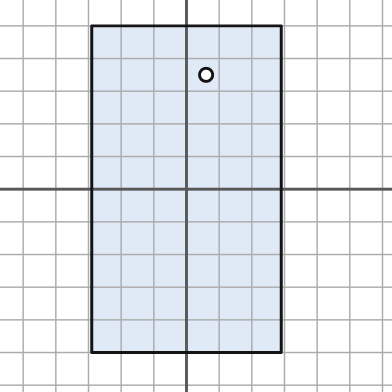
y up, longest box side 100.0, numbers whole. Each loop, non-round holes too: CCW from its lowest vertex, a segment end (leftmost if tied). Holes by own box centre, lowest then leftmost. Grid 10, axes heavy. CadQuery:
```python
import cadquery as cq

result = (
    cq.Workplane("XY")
    .moveTo(-29.0, -50.0)
    .lineTo(29.0, -50.0)
    .lineTo(29.0, 50.0)
    .lineTo(-29.0, 50.0)
    .close()
    .moveTo(6.0, 35.0)
    .circle(2.0)
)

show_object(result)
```